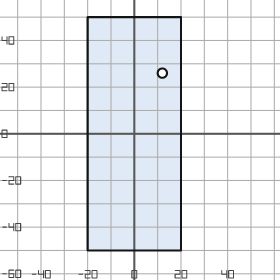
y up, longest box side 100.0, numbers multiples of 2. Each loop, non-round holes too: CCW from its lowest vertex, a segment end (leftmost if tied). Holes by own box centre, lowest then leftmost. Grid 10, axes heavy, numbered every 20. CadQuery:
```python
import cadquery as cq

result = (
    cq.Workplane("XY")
    .moveTo(-20.0, -50.0)
    .lineTo(20.0, -50.0)
    .lineTo(20.0, 50.0)
    .lineTo(-20.0, 50.0)
    .close()
    .moveTo(12.0, 26.0)
    .circle(2.0)
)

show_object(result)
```